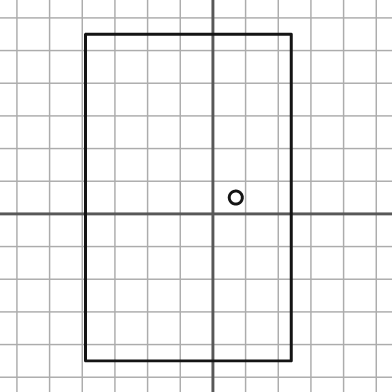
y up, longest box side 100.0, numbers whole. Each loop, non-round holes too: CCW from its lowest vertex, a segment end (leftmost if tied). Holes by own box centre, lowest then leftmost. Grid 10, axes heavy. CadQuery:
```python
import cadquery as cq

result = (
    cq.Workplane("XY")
    .moveTo(-39.0, -45.0)
    .lineTo(24.0, -45.0)
    .lineTo(24.0, 55.0)
    .lineTo(-39.0, 55.0)
    .close()
    .moveTo(7.0, 5.0)
    .circle(2.0)
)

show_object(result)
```